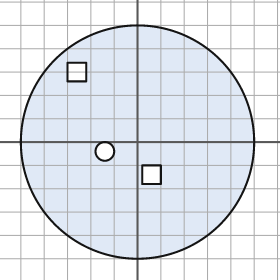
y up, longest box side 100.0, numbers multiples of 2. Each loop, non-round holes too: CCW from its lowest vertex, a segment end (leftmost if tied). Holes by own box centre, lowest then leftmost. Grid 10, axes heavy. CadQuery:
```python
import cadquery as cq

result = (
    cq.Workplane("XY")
    .moveTo(0.0, 0.0)
    .circle(50.0)
    .moveTo(2.0, -18.0)
    .lineTo(10.0, -18.0)
    .lineTo(10.0, -10.0)
    .lineTo(2.0, -10.0)
    .close()
    .moveTo(-14.0, -4.0)
    .circle(4.0)
    .moveTo(-30.0, 26.0)
    .lineTo(-22.0, 26.0)
    .lineTo(-22.0, 34.0)
    .lineTo(-30.0, 34.0)
    .close()
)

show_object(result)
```